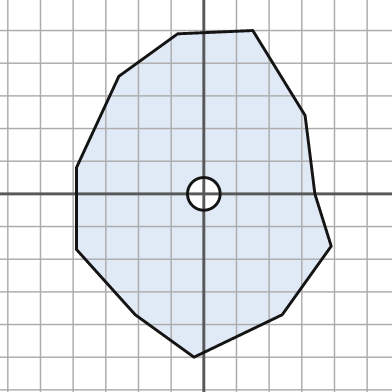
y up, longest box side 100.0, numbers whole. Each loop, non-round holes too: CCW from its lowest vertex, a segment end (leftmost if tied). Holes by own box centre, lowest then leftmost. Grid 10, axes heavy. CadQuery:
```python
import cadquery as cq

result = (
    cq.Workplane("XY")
    .moveTo(-3.0, -50.0)
    .lineTo(24.0, -37.0)
    .lineTo(39.0, -16.0)
    .lineTo(34.0, 0.0)
    .lineTo(31.0, 24.0)
    .lineTo(15.0, 50.0)
    .lineTo(-8.0, 49.0)
    .lineTo(-26.0, 36.0)
    .lineTo(-39.0, 8.0)
    .lineTo(-39.0, -17.0)
    .lineTo(-21.0, -37.0)
    .close()
    .moveTo(0.0, 0.0)
    .circle(5.0)
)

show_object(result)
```